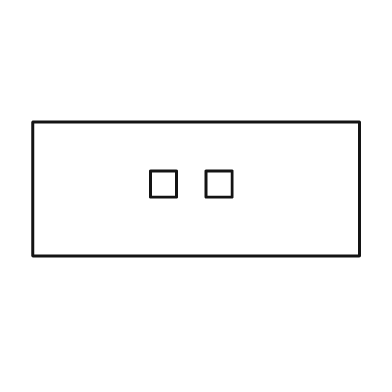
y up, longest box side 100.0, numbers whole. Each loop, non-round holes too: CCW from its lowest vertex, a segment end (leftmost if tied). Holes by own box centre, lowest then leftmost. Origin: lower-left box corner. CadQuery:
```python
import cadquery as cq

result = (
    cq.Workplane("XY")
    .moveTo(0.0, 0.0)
    .lineTo(100.0, 0.0)
    .lineTo(100.0, 41.0)
    .lineTo(0.0, 41.0)
    .close()
    .moveTo(36.0, 18.0)
    .lineTo(44.0, 18.0)
    .lineTo(44.0, 26.0)
    .lineTo(36.0, 26.0)
    .close()
    .moveTo(53.0, 18.0)
    .lineTo(61.0, 18.0)
    .lineTo(61.0, 26.0)
    .lineTo(53.0, 26.0)
    .close()
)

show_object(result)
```